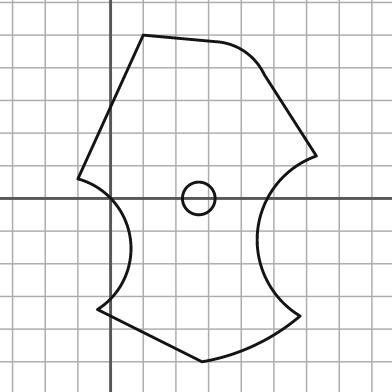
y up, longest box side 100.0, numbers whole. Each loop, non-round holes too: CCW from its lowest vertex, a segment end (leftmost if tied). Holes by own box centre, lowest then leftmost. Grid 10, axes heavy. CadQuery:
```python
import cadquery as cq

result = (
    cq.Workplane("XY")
    .moveTo(28.0, -50.0)
    .threePointArc((44.0, -45.0), (58.0, -36.0))
    .threePointArc((45.0, -10.0), (63.0, 13.0))
    .lineTo(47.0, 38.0)
    .threePointArc((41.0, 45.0), (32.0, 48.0))
    .lineTo(10.0, 50.0)
    .lineTo(-10.0, 6.0)
    .threePointArc((6.0, -12.0), (-4.0, -34.0))
    .close()
    .moveTo(27.0, 0.0)
    .circle(5.0)
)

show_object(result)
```